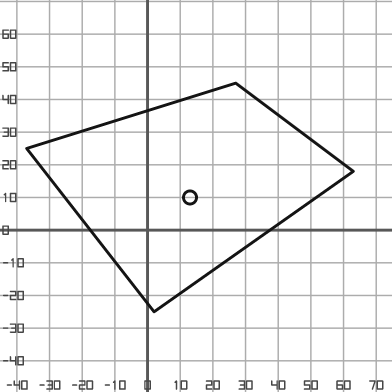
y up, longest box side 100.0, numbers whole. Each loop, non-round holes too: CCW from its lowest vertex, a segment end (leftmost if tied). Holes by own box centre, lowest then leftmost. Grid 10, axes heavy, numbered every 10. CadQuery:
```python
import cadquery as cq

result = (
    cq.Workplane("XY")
    .moveTo(2.0, -25.0)
    .lineTo(63.0, 18.0)
    .lineTo(27.0, 45.0)
    .lineTo(-37.0, 25.0)
    .close()
    .moveTo(13.0, 10.0)
    .circle(2.0)
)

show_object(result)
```